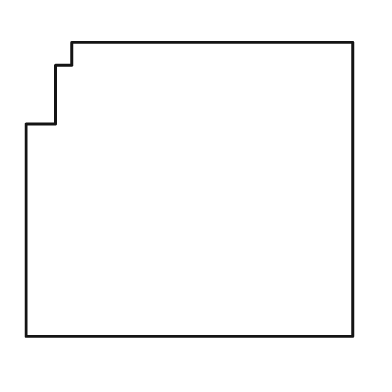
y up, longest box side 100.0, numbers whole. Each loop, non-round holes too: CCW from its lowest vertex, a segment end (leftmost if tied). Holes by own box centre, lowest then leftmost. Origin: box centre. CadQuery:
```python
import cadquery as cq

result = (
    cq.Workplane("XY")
    .moveTo(-50.0, -45.0)
    .lineTo(50.0, -45.0)
    .lineTo(50.0, 45.0)
    .lineTo(-36.0, 45.0)
    .lineTo(-36.0, 38.0)
    .lineTo(-41.0, 38.0)
    .lineTo(-41.0, 20.0)
    .lineTo(-50.0, 20.0)
    .close()
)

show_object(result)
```